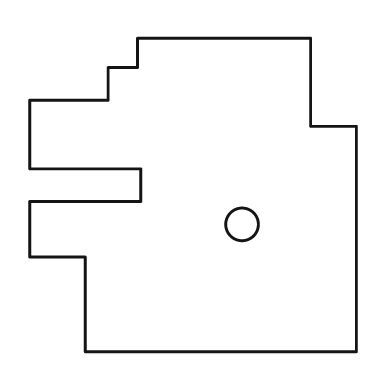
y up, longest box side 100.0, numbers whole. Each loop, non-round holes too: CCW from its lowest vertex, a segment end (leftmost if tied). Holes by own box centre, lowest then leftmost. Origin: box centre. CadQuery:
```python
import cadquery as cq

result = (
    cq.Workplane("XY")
    .moveTo(-33.0, -48.0)
    .lineTo(50.0, -48.0)
    .lineTo(50.0, 21.0)
    .lineTo(36.0, 21.0)
    .lineTo(36.0, 48.0)
    .lineTo(-17.0, 48.0)
    .lineTo(-17.0, 39.0)
    .lineTo(-26.0, 39.0)
    .lineTo(-26.0, 29.0)
    .lineTo(-50.0, 29.0)
    .lineTo(-50.0, 8.0)
    .lineTo(-16.0, 8.0)
    .lineTo(-16.0, -2.0)
    .lineTo(-50.0, -2.0)
    .lineTo(-50.0, -19.0)
    .lineTo(-33.0, -19.0)
    .close()
    .moveTo(15.0, -9.0)
    .circle(5.0)
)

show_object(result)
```